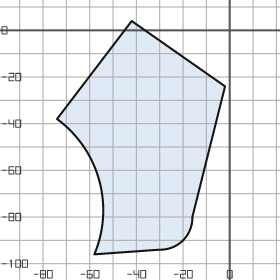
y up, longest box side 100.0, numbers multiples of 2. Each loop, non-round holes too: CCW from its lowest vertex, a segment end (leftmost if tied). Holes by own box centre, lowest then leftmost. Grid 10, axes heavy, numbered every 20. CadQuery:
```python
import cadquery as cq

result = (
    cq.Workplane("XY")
    .moveTo(-58.0, -96.0)
    .lineTo(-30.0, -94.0)
    .threePointArc((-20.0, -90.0), (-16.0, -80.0))
    .lineTo(-2.0, -24.0)
    .lineTo(-42.0, 4.0)
    .lineTo(-74.0, -38.0)
    .threePointArc((-56.0, -64.0), (-58.0, -96.0))
    .close()
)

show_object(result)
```